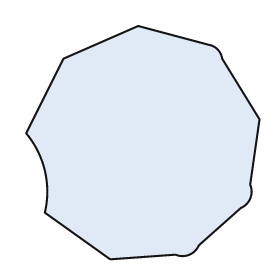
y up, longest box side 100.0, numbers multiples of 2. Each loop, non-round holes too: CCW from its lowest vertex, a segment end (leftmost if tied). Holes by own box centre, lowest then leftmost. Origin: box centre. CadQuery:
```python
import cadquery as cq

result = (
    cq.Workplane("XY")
    .moveTo(-14.0, -50.0)
    .lineTo(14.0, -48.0)
    .threePointArc((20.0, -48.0), (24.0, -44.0))
    .lineTo(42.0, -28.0)
    .threePointArc((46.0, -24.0), (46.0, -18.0))
    .lineTo(50.0, 10.0)
    .lineTo(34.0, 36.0)
    .threePointArc((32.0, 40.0), (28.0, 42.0))
    .lineTo(-2.0, 50.0)
    .lineTo(-34.0, 36.0)
    .lineTo(-50.0, 4.0)
    .threePointArc((-42.0, -12.0), (-42.0, -30.0))
    .close()
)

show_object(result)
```